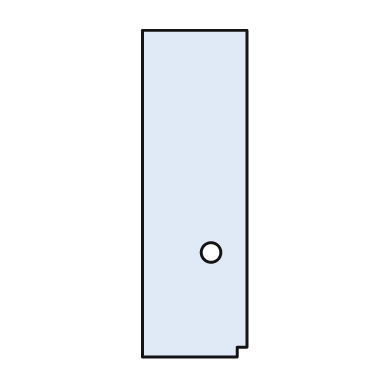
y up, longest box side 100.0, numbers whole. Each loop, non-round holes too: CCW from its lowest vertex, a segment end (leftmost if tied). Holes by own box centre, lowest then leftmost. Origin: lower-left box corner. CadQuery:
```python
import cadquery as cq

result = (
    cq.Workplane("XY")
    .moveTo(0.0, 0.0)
    .lineTo(29.0, 0.0)
    .lineTo(29.0, 3.0)
    .lineTo(32.0, 3.0)
    .lineTo(32.0, 100.0)
    .lineTo(0.0, 100.0)
    .close()
    .moveTo(21.0, 32.0)
    .circle(3.0)
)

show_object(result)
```